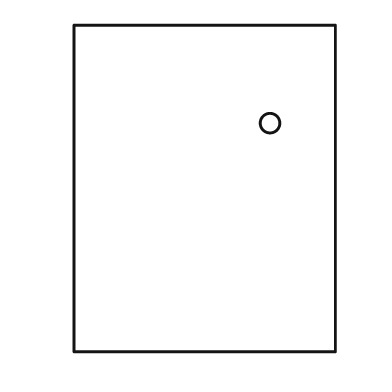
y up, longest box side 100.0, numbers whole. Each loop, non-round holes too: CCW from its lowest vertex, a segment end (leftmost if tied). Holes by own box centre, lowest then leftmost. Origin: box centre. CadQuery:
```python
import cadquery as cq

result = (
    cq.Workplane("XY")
    .moveTo(-40.0, -50.0)
    .lineTo(40.0, -50.0)
    .lineTo(40.0, 50.0)
    .lineTo(-40.0, 50.0)
    .close()
    .moveTo(20.0, 20.0)
    .circle(3.0)
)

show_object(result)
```